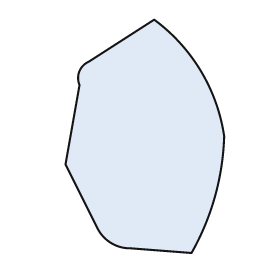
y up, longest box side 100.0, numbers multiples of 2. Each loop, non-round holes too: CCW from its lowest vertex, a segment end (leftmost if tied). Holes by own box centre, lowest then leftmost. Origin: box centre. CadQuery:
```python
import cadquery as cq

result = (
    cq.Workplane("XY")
    .moveTo(20.0, -50.0)
    .threePointArc((30.0, -26.0), (34.0, 0.0))
    .threePointArc((24.0, 28.0), (4.0, 50.0))
    .lineTo(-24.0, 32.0)
    .threePointArc((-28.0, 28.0), (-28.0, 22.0))
    .lineTo(-34.0, -12.0)
    .lineTo(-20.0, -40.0)
    .threePointArc((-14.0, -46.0), (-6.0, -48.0))
    .close()
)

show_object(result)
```